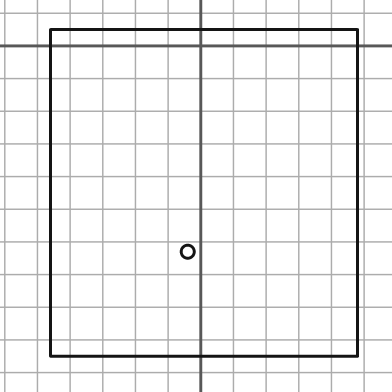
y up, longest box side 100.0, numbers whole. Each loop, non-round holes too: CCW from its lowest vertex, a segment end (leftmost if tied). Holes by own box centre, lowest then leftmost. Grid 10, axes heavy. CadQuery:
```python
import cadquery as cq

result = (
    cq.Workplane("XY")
    .moveTo(-46.0, -95.0)
    .lineTo(48.0, -95.0)
    .lineTo(48.0, 5.0)
    .lineTo(-46.0, 5.0)
    .close()
    .moveTo(-4.0, -63.0)
    .circle(2.0)
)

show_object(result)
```